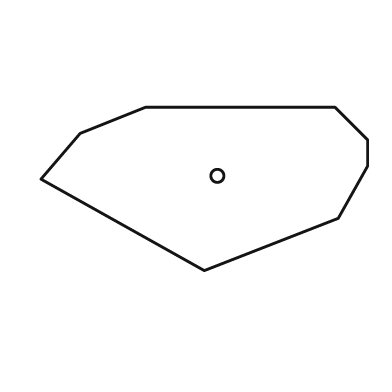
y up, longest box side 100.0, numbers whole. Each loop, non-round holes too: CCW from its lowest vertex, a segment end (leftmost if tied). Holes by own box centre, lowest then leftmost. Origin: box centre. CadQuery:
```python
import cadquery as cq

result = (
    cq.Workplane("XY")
    .moveTo(0.0, -25.0)
    .lineTo(41.0, -9.0)
    .lineTo(50.0, 7.0)
    .lineTo(50.0, 15.0)
    .lineTo(40.0, 25.0)
    .lineTo(-18.0, 25.0)
    .lineTo(-38.0, 17.0)
    .lineTo(-50.0, 3.0)
    .close()
    .moveTo(4.0, 4.0)
    .circle(2.0)
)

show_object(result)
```